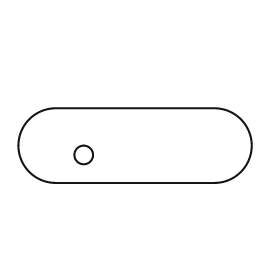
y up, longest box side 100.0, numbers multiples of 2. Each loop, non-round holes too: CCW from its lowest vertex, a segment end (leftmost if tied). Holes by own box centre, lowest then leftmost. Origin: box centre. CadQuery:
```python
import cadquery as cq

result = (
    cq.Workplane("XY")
    .moveTo(-34.0, -16.0)
    .lineTo(34.0, -16.0)
    .threePointArc((50.0, 0.0), (34.0, 16.0))
    .lineTo(-34.0, 16.0)
    .threePointArc((-50.0, 0.0), (-34.0, -16.0))
    .close()
    .moveTo(-22.0, -4.0)
    .circle(4.0)
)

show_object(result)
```